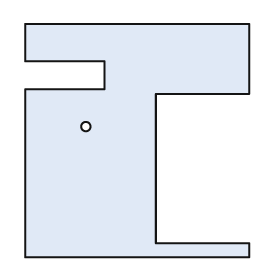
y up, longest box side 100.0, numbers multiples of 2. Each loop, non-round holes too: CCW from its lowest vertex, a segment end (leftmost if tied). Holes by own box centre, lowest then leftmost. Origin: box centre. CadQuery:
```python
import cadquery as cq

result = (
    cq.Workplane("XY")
    .moveTo(-48.0, -50.0)
    .lineTo(48.0, -50.0)
    .lineTo(48.0, -44.0)
    .lineTo(8.0, -44.0)
    .lineTo(8.0, 20.0)
    .lineTo(48.0, 20.0)
    .lineTo(48.0, 50.0)
    .lineTo(-48.0, 50.0)
    .lineTo(-48.0, 34.0)
    .lineTo(-14.0, 34.0)
    .lineTo(-14.0, 22.0)
    .lineTo(-48.0, 22.0)
    .close()
    .moveTo(-22.0, 6.0)
    .circle(2.0)
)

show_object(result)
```